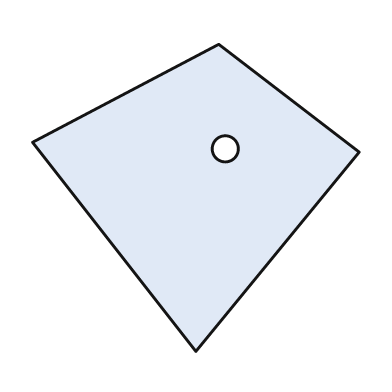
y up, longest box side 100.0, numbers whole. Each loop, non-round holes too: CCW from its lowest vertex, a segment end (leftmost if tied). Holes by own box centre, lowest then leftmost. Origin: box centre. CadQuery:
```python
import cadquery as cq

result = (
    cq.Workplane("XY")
    .moveTo(0.0, -47.0)
    .lineTo(50.0, 14.0)
    .lineTo(7.0, 47.0)
    .lineTo(-50.0, 17.0)
    .close()
    .moveTo(9.0, 15.0)
    .circle(4.0)
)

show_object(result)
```